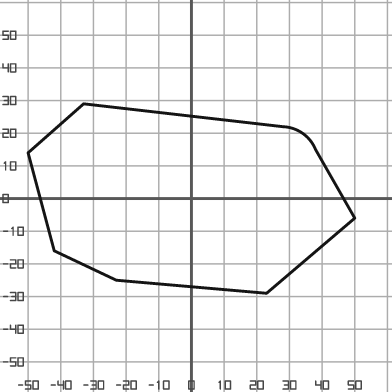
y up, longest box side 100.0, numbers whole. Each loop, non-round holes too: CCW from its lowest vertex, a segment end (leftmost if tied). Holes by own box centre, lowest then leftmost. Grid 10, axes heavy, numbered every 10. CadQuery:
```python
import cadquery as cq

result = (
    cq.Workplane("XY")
    .moveTo(23.0, -29.0)
    .lineTo(50.0, -6.0)
    .lineTo(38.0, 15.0)
    .threePointArc((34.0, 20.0), (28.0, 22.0))
    .lineTo(-33.0, 29.0)
    .lineTo(-50.0, 14.0)
    .lineTo(-42.0, -16.0)
    .lineTo(-23.0, -25.0)
    .close()
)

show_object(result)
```